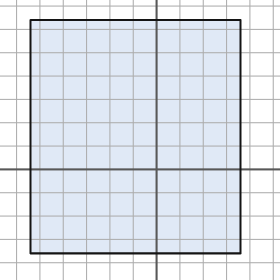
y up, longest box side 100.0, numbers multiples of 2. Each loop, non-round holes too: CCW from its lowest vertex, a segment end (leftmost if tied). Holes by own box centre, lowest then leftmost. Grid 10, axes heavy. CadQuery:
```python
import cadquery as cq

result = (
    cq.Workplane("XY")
    .moveTo(-54.0, -36.0)
    .lineTo(36.0, -36.0)
    .lineTo(36.0, 64.0)
    .lineTo(-54.0, 64.0)
    .close()
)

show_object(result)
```